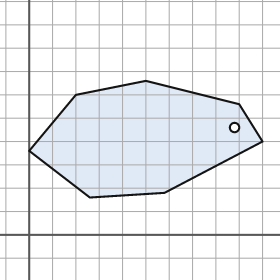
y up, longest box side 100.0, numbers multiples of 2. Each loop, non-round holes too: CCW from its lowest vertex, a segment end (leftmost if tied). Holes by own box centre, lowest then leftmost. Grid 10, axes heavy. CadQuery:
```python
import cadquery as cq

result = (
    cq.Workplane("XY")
    .moveTo(26.0, 16.0)
    .lineTo(58.0, 18.0)
    .lineTo(100.0, 40.0)
    .lineTo(90.0, 56.0)
    .lineTo(50.0, 66.0)
    .lineTo(20.0, 60.0)
    .lineTo(0.0, 36.0)
    .close()
    .moveTo(88.0, 46.0)
    .circle(2.0)
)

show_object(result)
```